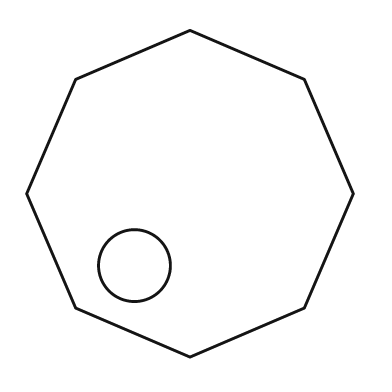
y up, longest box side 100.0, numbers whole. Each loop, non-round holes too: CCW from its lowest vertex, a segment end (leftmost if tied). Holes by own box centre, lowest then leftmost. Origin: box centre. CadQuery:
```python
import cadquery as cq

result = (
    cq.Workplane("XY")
    .moveTo(0.0, -50.0)
    .lineTo(35.0, -35.0)
    .lineTo(50.0, 0.0)
    .lineTo(35.0, 35.0)
    .lineTo(0.0, 50.0)
    .lineTo(-35.0, 35.0)
    .lineTo(-50.0, 0.0)
    .lineTo(-35.0, -35.0)
    .close()
    .moveTo(-17.0, -22.0)
    .circle(11.0)
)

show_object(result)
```